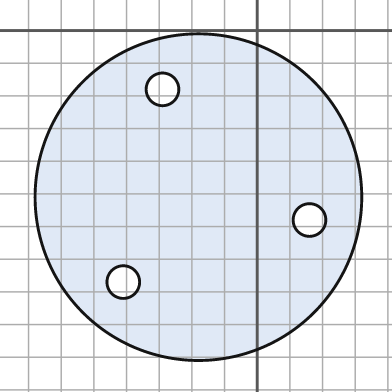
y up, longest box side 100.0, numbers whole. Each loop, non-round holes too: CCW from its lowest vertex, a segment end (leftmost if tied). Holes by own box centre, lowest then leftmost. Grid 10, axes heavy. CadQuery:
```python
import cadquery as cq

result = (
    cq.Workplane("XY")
    .moveTo(-18.0, -51.0)
    .circle(50.0)
    .moveTo(-41.0, -77.0)
    .circle(5.0)
    .moveTo(16.0, -58.0)
    .circle(5.0)
    .moveTo(-29.0, -18.0)
    .circle(5.0)
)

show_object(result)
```